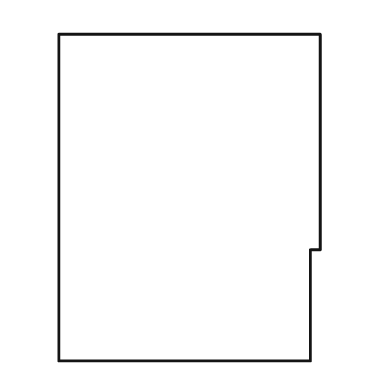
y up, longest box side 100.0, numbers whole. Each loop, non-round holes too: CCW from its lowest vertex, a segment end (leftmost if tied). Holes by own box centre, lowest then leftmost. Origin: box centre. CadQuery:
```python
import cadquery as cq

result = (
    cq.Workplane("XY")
    .moveTo(-40.0, -50.0)
    .lineTo(37.0, -50.0)
    .lineTo(37.0, -16.0)
    .lineTo(40.0, -16.0)
    .lineTo(40.0, 50.0)
    .lineTo(-40.0, 50.0)
    .close()
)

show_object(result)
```